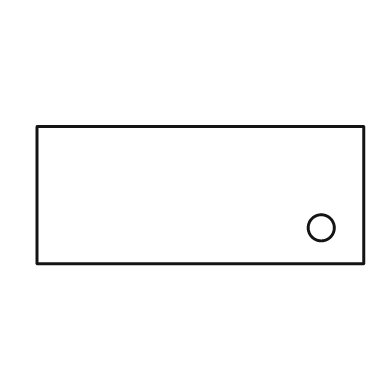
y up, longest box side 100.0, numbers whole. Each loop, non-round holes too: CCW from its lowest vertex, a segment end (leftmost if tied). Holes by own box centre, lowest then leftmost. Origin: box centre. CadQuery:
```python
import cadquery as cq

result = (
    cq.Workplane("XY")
    .moveTo(-50.0, -21.0)
    .lineTo(50.0, -21.0)
    .lineTo(50.0, 21.0)
    .lineTo(-50.0, 21.0)
    .close()
    .moveTo(37.0, -10.0)
    .circle(4.0)
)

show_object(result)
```